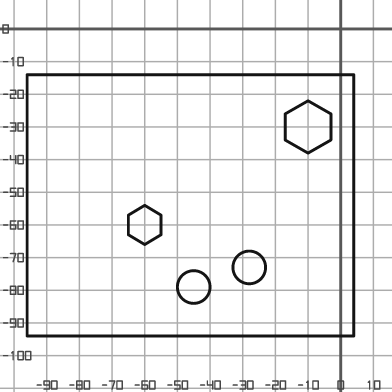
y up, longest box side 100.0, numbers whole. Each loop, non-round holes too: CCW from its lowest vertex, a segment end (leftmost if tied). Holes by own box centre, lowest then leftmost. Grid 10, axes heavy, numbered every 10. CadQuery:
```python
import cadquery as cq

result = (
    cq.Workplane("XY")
    .moveTo(-96.0, -94.0)
    .lineTo(4.0, -94.0)
    .lineTo(4.0, -14.0)
    .lineTo(-96.0, -14.0)
    .close()
    .moveTo(-45.0, -79.0)
    .circle(5.0)
    .moveTo(-28.0, -73.0)
    .circle(5.0)
    .moveTo(-60.0, -66.0)
    .lineTo(-55.0, -63.0)
    .lineTo(-55.0, -57.0)
    .lineTo(-60.0, -54.0)
    .lineTo(-65.0, -57.0)
    .lineTo(-65.0, -63.0)
    .close()
    .moveTo(-10.0, -38.0)
    .lineTo(-3.0, -34.0)
    .lineTo(-3.0, -26.0)
    .lineTo(-10.0, -22.0)
    .lineTo(-17.0, -26.0)
    .lineTo(-17.0, -34.0)
    .close()
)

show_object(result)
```